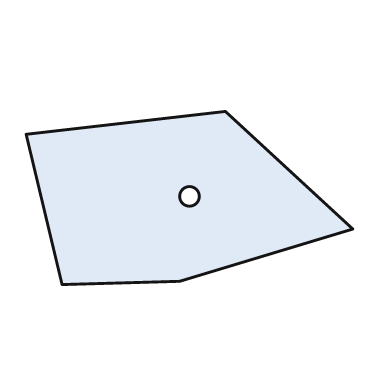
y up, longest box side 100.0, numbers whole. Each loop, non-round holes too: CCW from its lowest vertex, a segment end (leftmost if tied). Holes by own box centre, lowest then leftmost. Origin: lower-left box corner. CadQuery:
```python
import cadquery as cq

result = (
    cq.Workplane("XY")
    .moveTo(11.0, 0.0)
    .lineTo(47.0, 1.0)
    .lineTo(100.0, 17.0)
    .lineTo(61.0, 53.0)
    .lineTo(0.0, 46.0)
    .close()
    .moveTo(50.0, 27.0)
    .circle(3.0)
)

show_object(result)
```